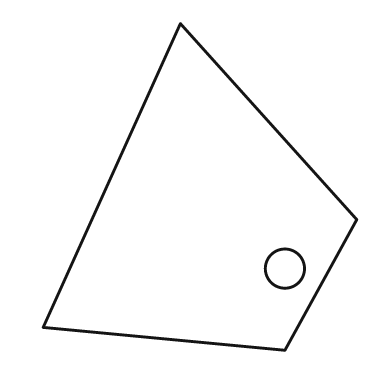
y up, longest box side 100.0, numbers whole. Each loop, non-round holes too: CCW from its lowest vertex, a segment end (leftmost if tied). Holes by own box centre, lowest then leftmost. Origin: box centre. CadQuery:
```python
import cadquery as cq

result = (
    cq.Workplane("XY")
    .moveTo(26.0, -50.0)
    .lineTo(48.0, -10.0)
    .lineTo(-6.0, 50.0)
    .lineTo(-48.0, -43.0)
    .close()
    .moveTo(26.0, -25.0)
    .circle(6.0)
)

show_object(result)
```